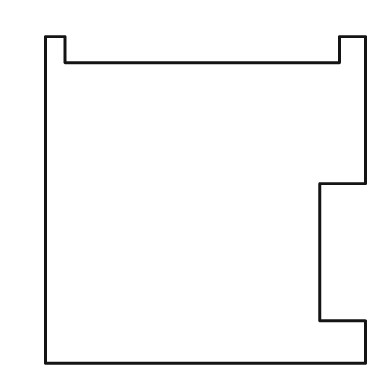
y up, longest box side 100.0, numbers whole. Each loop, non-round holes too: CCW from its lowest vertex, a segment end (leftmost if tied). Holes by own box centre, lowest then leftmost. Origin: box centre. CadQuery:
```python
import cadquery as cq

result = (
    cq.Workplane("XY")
    .moveTo(-49.0, -50.0)
    .lineTo(49.0, -50.0)
    .lineTo(49.0, -37.0)
    .lineTo(35.0, -37.0)
    .lineTo(35.0, 5.0)
    .lineTo(49.0, 5.0)
    .lineTo(49.0, 50.0)
    .lineTo(41.0, 50.0)
    .lineTo(41.0, 42.0)
    .lineTo(-43.0, 42.0)
    .lineTo(-43.0, 50.0)
    .lineTo(-49.0, 50.0)
    .close()
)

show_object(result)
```